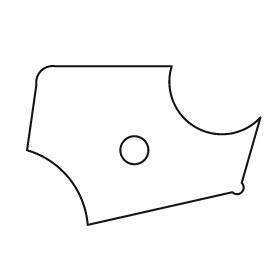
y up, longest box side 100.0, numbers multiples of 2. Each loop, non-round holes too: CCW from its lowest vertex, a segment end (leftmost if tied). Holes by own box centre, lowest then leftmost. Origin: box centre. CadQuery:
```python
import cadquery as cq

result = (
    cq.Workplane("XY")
    .moveTo(-24.0, -34.0)
    .lineTo(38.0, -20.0)
    .threePointArc((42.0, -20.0), (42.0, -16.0))
    .lineTo(50.0, 12.0)
    .threePointArc((22.0, 8.0), (12.0, 34.0))
    .lineTo(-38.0, 34.0)
    .threePointArc((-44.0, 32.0), (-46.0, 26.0))
    .lineTo(-50.0, -2.0)
    .threePointArc((-32.0, -14.0), (-24.0, -34.0))
    .close()
    .moveTo(-4.0, -2.0)
    .circle(6.0)
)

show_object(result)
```